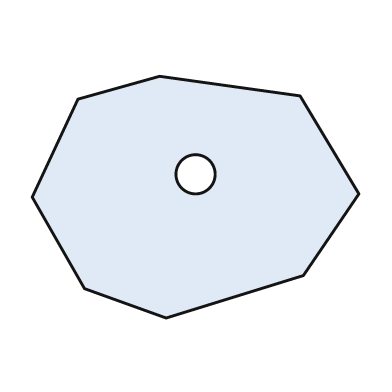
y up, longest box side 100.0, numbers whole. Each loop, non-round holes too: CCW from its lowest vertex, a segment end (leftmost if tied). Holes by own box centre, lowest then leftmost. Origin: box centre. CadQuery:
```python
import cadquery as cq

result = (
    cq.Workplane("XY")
    .moveTo(-9.0, -37.0)
    .lineTo(33.0, -24.0)
    .lineTo(50.0, 1.0)
    .lineTo(32.0, 31.0)
    .lineTo(-11.0, 37.0)
    .lineTo(-36.0, 30.0)
    .lineTo(-50.0, 0.0)
    .lineTo(-34.0, -28.0)
    .close()
    .moveTo(0.0, 7.0)
    .circle(6.0)
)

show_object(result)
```